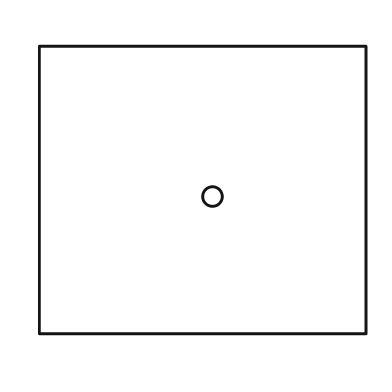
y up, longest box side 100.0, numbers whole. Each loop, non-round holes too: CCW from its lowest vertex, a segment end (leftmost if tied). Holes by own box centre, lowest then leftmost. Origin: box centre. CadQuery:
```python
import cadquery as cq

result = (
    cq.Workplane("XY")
    .moveTo(-50.0, -44.0)
    .lineTo(50.0, -44.0)
    .lineTo(50.0, 44.0)
    .lineTo(-50.0, 44.0)
    .close()
    .moveTo(3.0, -2.0)
    .circle(3.0)
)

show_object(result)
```